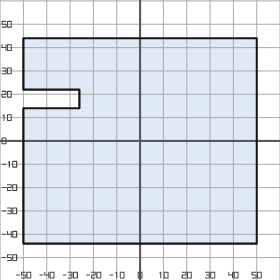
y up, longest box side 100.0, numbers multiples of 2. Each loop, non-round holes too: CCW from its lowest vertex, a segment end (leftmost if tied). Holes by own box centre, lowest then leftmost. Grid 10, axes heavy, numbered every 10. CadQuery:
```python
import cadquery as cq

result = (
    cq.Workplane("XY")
    .moveTo(-50.0, -44.0)
    .lineTo(50.0, -44.0)
    .lineTo(50.0, 44.0)
    .lineTo(-50.0, 44.0)
    .lineTo(-50.0, 22.0)
    .lineTo(-26.0, 22.0)
    .lineTo(-26.0, 14.0)
    .lineTo(-50.0, 14.0)
    .close()
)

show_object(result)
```